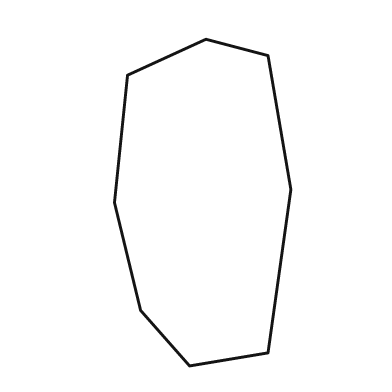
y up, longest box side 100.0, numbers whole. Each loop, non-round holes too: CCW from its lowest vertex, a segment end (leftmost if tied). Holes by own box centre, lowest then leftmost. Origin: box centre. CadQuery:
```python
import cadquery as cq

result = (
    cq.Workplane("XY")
    .moveTo(-4.0, -50.0)
    .lineTo(20.0, -46.0)
    .lineTo(27.0, 4.0)
    .lineTo(20.0, 45.0)
    .lineTo(1.0, 50.0)
    .lineTo(-23.0, 39.0)
    .lineTo(-27.0, 0.0)
    .lineTo(-19.0, -33.0)
    .close()
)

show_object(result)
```